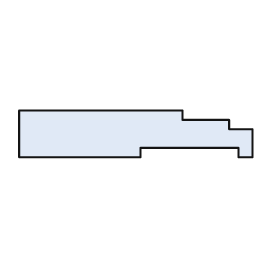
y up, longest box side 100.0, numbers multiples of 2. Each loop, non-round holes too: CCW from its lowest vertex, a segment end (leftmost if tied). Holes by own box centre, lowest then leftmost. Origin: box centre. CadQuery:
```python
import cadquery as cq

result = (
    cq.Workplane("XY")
    .moveTo(-50.0, -10.0)
    .lineTo(2.0, -10.0)
    .lineTo(2.0, -6.0)
    .lineTo(44.0, -6.0)
    .lineTo(44.0, -10.0)
    .lineTo(50.0, -10.0)
    .lineTo(50.0, 2.0)
    .lineTo(40.0, 2.0)
    .lineTo(40.0, 6.0)
    .lineTo(20.0, 6.0)
    .lineTo(20.0, 10.0)
    .lineTo(-50.0, 10.0)
    .close()
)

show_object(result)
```